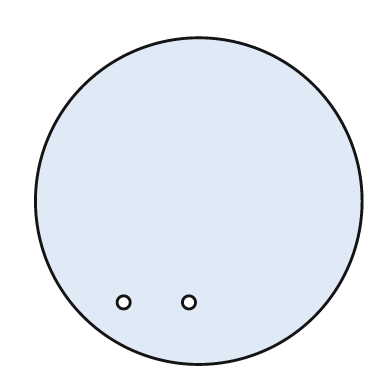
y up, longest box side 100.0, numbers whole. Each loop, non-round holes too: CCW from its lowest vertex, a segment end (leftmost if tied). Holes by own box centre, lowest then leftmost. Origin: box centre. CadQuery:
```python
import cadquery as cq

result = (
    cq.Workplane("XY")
    .moveTo(0.0, 0.0)
    .circle(50.0)
    .moveTo(-23.0, -31.0)
    .circle(2.0)
    .moveTo(-3.0, -31.0)
    .circle(2.0)
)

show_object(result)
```